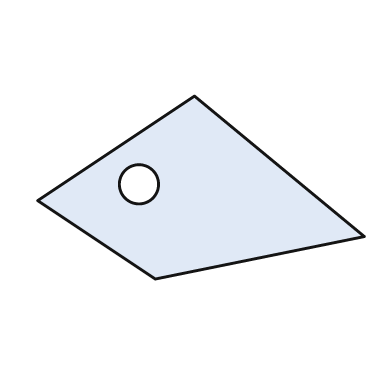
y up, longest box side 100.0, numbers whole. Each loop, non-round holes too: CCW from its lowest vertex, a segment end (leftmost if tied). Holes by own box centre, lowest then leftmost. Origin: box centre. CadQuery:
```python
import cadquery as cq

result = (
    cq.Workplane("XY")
    .moveTo(-14.0, -28.0)
    .lineTo(50.0, -15.0)
    .lineTo(-2.0, 28.0)
    .lineTo(-50.0, -4.0)
    .close()
    .moveTo(-19.0, 1.0)
    .circle(6.0)
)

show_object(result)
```